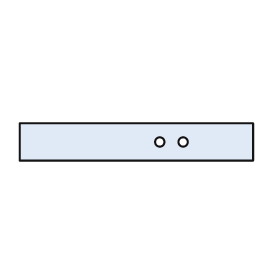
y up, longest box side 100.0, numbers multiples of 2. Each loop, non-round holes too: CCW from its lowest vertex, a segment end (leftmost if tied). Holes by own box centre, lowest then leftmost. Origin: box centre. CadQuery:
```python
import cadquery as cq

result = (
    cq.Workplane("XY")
    .moveTo(-50.0, -8.0)
    .lineTo(50.0, -8.0)
    .lineTo(50.0, 8.0)
    .lineTo(-50.0, 8.0)
    .close()
    .moveTo(10.0, 0.0)
    .circle(2.0)
    .moveTo(20.0, 0.0)
    .circle(2.0)
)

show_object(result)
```